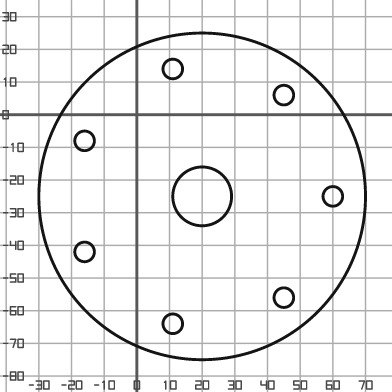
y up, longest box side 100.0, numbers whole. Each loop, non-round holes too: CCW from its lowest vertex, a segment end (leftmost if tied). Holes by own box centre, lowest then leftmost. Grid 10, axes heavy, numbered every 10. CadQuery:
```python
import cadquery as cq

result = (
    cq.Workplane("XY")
    .moveTo(20.0, -25.0)
    .circle(50.0)
    .moveTo(11.0, -64.0)
    .circle(3.0)
    .moveTo(45.0, -56.0)
    .circle(3.0)
    .moveTo(-16.0, -42.0)
    .circle(3.0)
    .moveTo(20.0, -25.0)
    .circle(9.0)
    .moveTo(60.0, -25.0)
    .circle(3.0)
    .moveTo(-16.0, -8.0)
    .circle(3.0)
    .moveTo(45.0, 6.0)
    .circle(3.0)
    .moveTo(11.0, 14.0)
    .circle(3.0)
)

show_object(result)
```